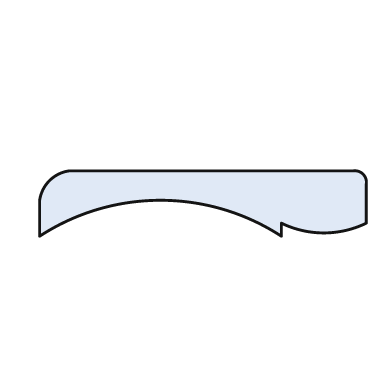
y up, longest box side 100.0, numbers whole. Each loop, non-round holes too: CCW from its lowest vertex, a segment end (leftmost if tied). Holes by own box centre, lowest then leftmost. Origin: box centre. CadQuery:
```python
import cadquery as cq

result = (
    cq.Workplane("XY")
    .moveTo(-50.0, -10.0)
    .threePointArc((-13.0, 1.0), (24.0, -10.0))
    .lineTo(24.0, -6.0)
    .threePointArc((37.0, -9.0), (50.0, -6.0))
    .lineTo(50.0, 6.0)
    .threePointArc((49.0, 9.0), (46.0, 10.0))
    .lineTo(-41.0, 10.0)
    .threePointArc((-47.0, 7.0), (-50.0, 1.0))
    .close()
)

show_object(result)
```